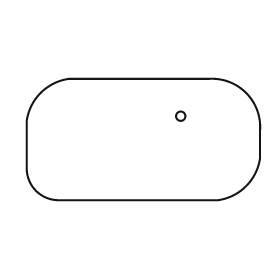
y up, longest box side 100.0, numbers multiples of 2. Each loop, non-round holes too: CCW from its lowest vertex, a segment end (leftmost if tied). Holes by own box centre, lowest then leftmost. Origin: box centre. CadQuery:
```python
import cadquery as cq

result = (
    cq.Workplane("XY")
    .moveTo(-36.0, -26.0)
    .lineTo(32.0, -26.0)
    .threePointArc((44.0, -20.0), (50.0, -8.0))
    .lineTo(50.0, 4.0)
    .threePointArc((44.0, 20.0), (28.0, 26.0))
    .lineTo(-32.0, 26.0)
    .threePointArc((-44.0, 20.0), (-50.0, 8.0))
    .lineTo(-50.0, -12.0)
    .threePointArc((-46.0, -22.0), (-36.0, -26.0))
    .close()
    .moveTo(16.0, 10.0)
    .circle(2.0)
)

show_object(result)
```